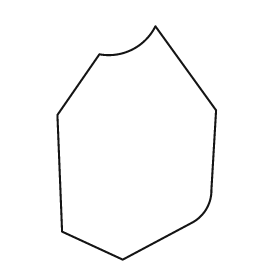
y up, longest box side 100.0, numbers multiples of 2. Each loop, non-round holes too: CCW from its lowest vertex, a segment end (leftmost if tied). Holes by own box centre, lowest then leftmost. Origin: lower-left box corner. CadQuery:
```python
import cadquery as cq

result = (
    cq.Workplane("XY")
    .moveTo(28.0, 0.0)
    .lineTo(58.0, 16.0)
    .threePointArc((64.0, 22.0), (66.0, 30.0))
    .lineTo(68.0, 64.0)
    .lineTo(42.0, 100.0)
    .threePointArc((32.0, 90.0), (18.0, 88.0))
    .lineTo(0.0, 62.0)
    .lineTo(2.0, 12.0)
    .close()
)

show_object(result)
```